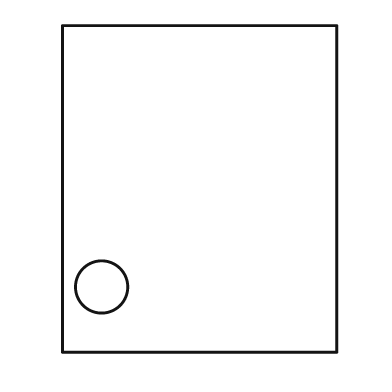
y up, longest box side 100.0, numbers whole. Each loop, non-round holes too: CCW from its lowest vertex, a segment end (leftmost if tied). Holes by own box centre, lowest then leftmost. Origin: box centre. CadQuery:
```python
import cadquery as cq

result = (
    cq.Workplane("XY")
    .moveTo(-42.0, -50.0)
    .lineTo(42.0, -50.0)
    .lineTo(42.0, 50.0)
    .lineTo(-42.0, 50.0)
    .close()
    .moveTo(-30.0, -30.0)
    .circle(8.0)
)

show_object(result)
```